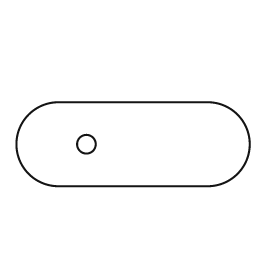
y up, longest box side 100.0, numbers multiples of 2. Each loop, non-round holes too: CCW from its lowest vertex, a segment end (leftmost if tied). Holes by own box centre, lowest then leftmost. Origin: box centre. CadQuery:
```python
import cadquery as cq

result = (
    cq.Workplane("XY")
    .moveTo(-32.0, -18.0)
    .lineTo(32.0, -18.0)
    .threePointArc((50.0, 0.0), (32.0, 18.0))
    .lineTo(-32.0, 18.0)
    .threePointArc((-50.0, 0.0), (-32.0, -18.0))
    .close()
    .moveTo(-20.0, 0.0)
    .circle(4.0)
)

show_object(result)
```